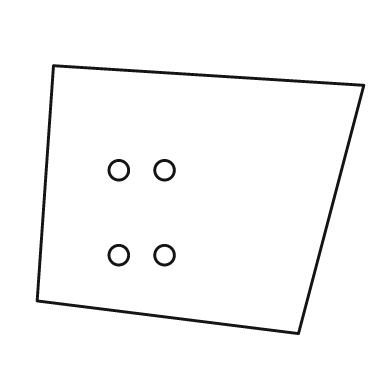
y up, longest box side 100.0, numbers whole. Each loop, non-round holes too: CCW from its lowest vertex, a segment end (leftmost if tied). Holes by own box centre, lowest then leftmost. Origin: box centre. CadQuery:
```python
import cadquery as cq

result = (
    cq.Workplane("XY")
    .moveTo(30.0, -41.0)
    .lineTo(50.0, 35.0)
    .lineTo(-45.0, 41.0)
    .lineTo(-50.0, -31.0)
    .close()
    .moveTo(-25.0, -17.0)
    .circle(3.0)
    .moveTo(-11.0, -17.0)
    .circle(3.0)
    .moveTo(-25.0, 9.0)
    .circle(3.0)
    .moveTo(-11.0, 9.0)
    .circle(3.0)
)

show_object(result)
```